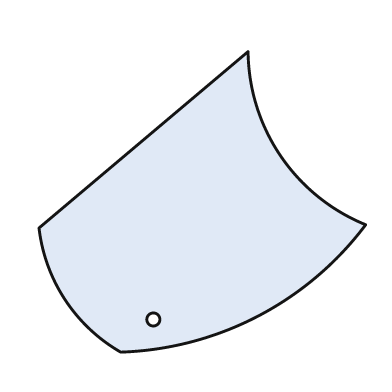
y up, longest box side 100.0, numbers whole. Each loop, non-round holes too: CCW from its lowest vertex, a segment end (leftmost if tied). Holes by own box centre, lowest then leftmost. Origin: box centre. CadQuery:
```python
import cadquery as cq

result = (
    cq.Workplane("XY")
    .moveTo(-25.0, -46.0)
    .threePointArc((17.0, -35.0), (50.0, -7.0))
    .threePointArc((24.0, 14.0), (14.0, 46.0))
    .lineTo(-50.0, -8.0)
    .threePointArc((-42.0, -30.0), (-25.0, -46.0))
    .close()
    .moveTo(-15.0, -36.0)
    .circle(2.0)
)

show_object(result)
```